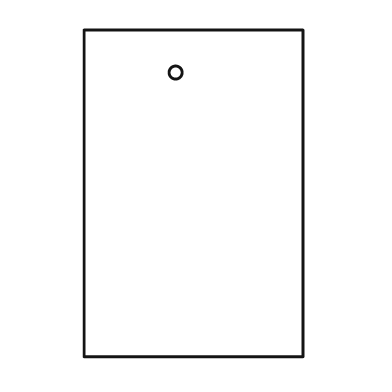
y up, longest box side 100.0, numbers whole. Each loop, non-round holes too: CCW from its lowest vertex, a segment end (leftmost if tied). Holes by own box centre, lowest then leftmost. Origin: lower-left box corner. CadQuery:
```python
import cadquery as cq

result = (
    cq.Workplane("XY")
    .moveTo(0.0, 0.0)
    .lineTo(67.0, 0.0)
    .lineTo(67.0, 100.0)
    .lineTo(0.0, 100.0)
    .close()
    .moveTo(28.0, 87.0)
    .circle(2.0)
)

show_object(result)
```